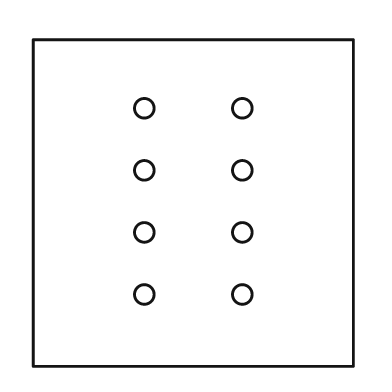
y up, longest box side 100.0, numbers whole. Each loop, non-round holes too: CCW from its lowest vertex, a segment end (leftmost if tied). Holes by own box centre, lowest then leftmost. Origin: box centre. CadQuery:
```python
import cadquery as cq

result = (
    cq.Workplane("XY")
    .moveTo(-49.0, -50.0)
    .lineTo(49.0, -50.0)
    .lineTo(49.0, 50.0)
    .lineTo(-49.0, 50.0)
    .close()
    .moveTo(-15.0, -28.0)
    .circle(3.0)
    .moveTo(15.0, -28.0)
    .circle(3.0)
    .moveTo(-15.0, -9.0)
    .circle(3.0)
    .moveTo(15.0, -9.0)
    .circle(3.0)
    .moveTo(-15.0, 10.0)
    .circle(3.0)
    .moveTo(15.0, 10.0)
    .circle(3.0)
    .moveTo(-15.0, 29.0)
    .circle(3.0)
    .moveTo(15.0, 29.0)
    .circle(3.0)
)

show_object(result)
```